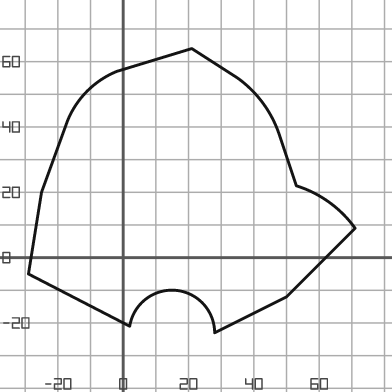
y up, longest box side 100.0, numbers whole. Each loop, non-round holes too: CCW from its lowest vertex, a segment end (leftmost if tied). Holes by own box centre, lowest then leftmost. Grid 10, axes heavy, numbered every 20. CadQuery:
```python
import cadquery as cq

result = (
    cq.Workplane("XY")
    .moveTo(28.0, -23.0)
    .lineTo(50.0, -12.0)
    .lineTo(71.0, 9.0)
    .threePointArc((63.0, 17.0), (53.0, 22.0))
    .lineTo(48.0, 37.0)
    .threePointArc((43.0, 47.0), (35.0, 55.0))
    .lineTo(21.0, 64.0)
    .lineTo(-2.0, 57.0)
    .threePointArc((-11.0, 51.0), (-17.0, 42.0))
    .lineTo(-25.0, 20.0)
    .lineTo(-29.0, -5.0)
    .lineTo(2.0, -21.0)
    .threePointArc((16.0, -10.0), (28.0, -23.0))
    .close()
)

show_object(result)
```